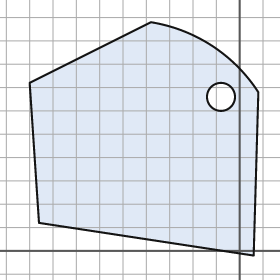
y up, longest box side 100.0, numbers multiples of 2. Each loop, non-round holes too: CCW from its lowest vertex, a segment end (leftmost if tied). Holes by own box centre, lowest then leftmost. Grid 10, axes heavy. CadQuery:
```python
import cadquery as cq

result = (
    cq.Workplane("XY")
    .moveTo(6.0, -2.0)
    .lineTo(8.0, 68.0)
    .threePointArc((-12.0, 88.0), (-38.0, 98.0))
    .lineTo(-90.0, 72.0)
    .lineTo(-86.0, 12.0)
    .close()
    .moveTo(-8.0, 66.0)
    .circle(6.0)
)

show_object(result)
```